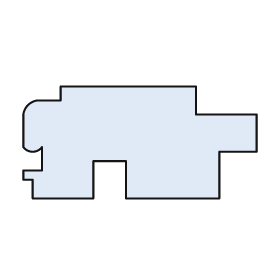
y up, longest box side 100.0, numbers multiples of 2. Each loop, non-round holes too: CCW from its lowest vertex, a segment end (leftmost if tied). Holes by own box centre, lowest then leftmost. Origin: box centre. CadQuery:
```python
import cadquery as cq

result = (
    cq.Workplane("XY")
    .moveTo(-46.0, -24.0)
    .lineTo(-20.0, -24.0)
    .lineTo(-20.0, -8.0)
    .lineTo(-6.0, -8.0)
    .lineTo(-6.0, -24.0)
    .lineTo(34.0, -24.0)
    .lineTo(34.0, -4.0)
    .lineTo(50.0, -4.0)
    .lineTo(50.0, 12.0)
    .lineTo(24.0, 12.0)
    .lineTo(24.0, 24.0)
    .lineTo(-34.0, 24.0)
    .lineTo(-34.0, 18.0)
    .lineTo(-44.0, 18.0)
    .threePointArc((-48.0, 16.0), (-50.0, 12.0))
    .lineTo(-50.0, -2.0)
    .threePointArc((-46.0, -4.0), (-42.0, -2.0))
    .lineTo(-42.0, -12.0)
    .lineTo(-50.0, -12.0)
    .lineTo(-50.0, -16.0)
    .lineTo(-46.0, -16.0)
    .close()
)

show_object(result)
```